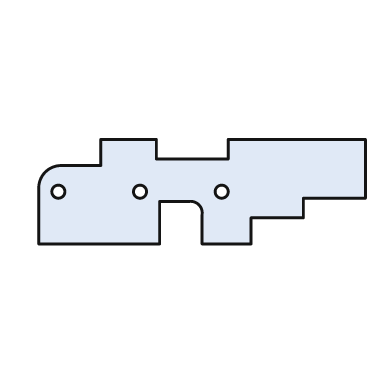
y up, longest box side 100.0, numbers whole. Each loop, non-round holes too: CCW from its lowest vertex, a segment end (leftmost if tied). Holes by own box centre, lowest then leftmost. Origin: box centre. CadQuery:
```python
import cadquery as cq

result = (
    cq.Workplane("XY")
    .moveTo(-50.0, -16.0)
    .lineTo(-13.0, -16.0)
    .lineTo(-13.0, -3.0)
    .lineTo(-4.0, -3.0)
    .threePointArc((-1.0, -4.0), (0.0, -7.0))
    .lineTo(0.0, -16.0)
    .lineTo(15.0, -16.0)
    .lineTo(15.0, -8.0)
    .lineTo(31.0, -8.0)
    .lineTo(31.0, -2.0)
    .lineTo(50.0, -2.0)
    .lineTo(50.0, 16.0)
    .lineTo(8.0, 16.0)
    .lineTo(8.0, 10.0)
    .lineTo(-14.0, 10.0)
    .lineTo(-14.0, 16.0)
    .lineTo(-31.0, 16.0)
    .lineTo(-31.0, 8.0)
    .lineTo(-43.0, 8.0)
    .threePointArc((-48.0, 6.0), (-50.0, 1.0))
    .close()
    .moveTo(-44.0, 0.0)
    .circle(2.0)
    .moveTo(-19.0, 0.0)
    .circle(2.0)
    .moveTo(6.0, 0.0)
    .circle(2.0)
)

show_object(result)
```